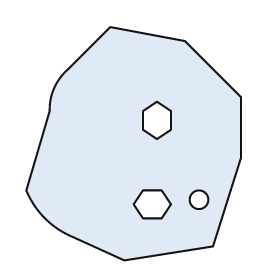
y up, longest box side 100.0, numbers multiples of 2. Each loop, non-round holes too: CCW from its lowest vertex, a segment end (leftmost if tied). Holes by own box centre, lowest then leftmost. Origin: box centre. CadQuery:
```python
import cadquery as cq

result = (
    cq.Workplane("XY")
    .moveTo(-4.0, -50.0)
    .lineTo(34.0, -44.0)
    .lineTo(46.0, -6.0)
    .lineTo(46.0, 20.0)
    .lineTo(22.0, 44.0)
    .lineTo(-10.0, 50.0)
    .lineTo(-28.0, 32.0)
    .threePointArc((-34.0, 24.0), (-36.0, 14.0))
    .lineTo(-46.0, -20.0)
    .threePointArc((-38.0, -32.0), (-26.0, -40.0))
    .close()
    .moveTo(4.0, -32.0)
    .lineTo(12.0, -32.0)
    .lineTo(16.0, -26.0)
    .lineTo(12.0, -20.0)
    .lineTo(4.0, -20.0)
    .lineTo(0.0, -26.0)
    .close()
    .moveTo(28.0, -24.0)
    .circle(4.0)
    .moveTo(10.0, 2.0)
    .lineTo(16.0, 6.0)
    .lineTo(16.0, 14.0)
    .lineTo(10.0, 18.0)
    .lineTo(4.0, 14.0)
    .lineTo(4.0, 6.0)
    .close()
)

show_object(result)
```